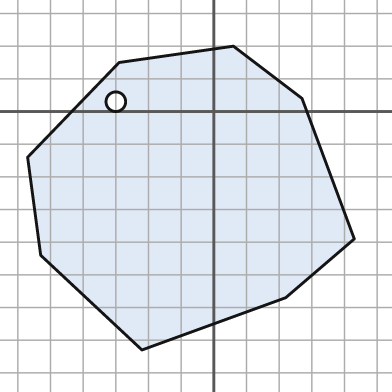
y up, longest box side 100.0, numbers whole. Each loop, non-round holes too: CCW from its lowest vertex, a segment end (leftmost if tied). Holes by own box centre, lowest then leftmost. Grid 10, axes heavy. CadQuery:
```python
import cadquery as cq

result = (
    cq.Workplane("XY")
    .moveTo(-22.0, -73.0)
    .lineTo(22.0, -57.0)
    .lineTo(43.0, -39.0)
    .lineTo(27.0, 4.0)
    .lineTo(6.0, 20.0)
    .lineTo(-29.0, 15.0)
    .lineTo(-57.0, -14.0)
    .lineTo(-53.0, -44.0)
    .close()
    .moveTo(-30.0, 3.0)
    .circle(3.0)
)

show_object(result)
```